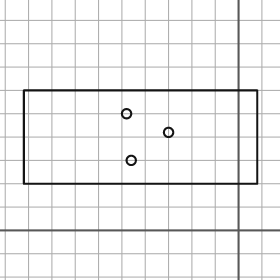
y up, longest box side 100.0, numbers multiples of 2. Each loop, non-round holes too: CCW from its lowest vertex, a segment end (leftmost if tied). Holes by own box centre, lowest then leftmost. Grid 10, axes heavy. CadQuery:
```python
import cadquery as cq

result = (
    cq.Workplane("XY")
    .moveTo(-92.0, 20.0)
    .lineTo(8.0, 20.0)
    .lineTo(8.0, 60.0)
    .lineTo(-92.0, 60.0)
    .close()
    .moveTo(-46.0, 30.0)
    .circle(2.0)
    .moveTo(-30.0, 42.0)
    .circle(2.0)
    .moveTo(-48.0, 50.0)
    .circle(2.0)
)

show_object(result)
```